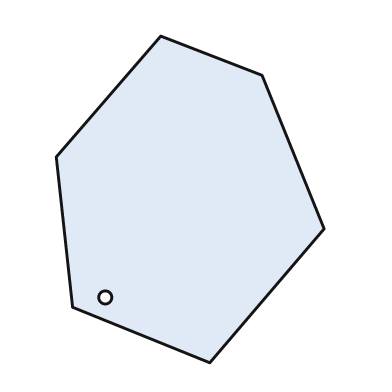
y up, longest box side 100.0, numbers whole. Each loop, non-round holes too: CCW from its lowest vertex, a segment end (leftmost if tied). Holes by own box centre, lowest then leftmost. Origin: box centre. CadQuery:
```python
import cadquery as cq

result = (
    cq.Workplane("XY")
    .moveTo(6.0, -50.0)
    .lineTo(41.0, -9.0)
    .lineTo(22.0, 38.0)
    .lineTo(-9.0, 50.0)
    .lineTo(-41.0, 13.0)
    .lineTo(-36.0, -33.0)
    .close()
    .moveTo(-26.0, -30.0)
    .circle(2.0)
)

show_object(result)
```